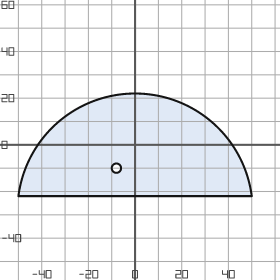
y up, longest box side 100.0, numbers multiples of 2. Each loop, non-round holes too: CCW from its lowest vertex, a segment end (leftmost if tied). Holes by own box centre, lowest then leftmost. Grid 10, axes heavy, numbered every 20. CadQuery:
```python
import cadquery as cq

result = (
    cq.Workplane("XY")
    .moveTo(-50.0, -22.0)
    .lineTo(50.0, -22.0)
    .threePointArc((0.0, 22.0), (-50.0, -22.0))
    .close()
    .moveTo(-8.0, -10.0)
    .circle(2.0)
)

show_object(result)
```